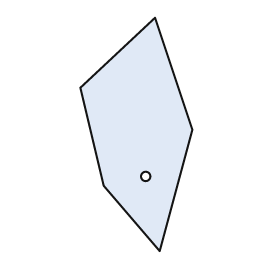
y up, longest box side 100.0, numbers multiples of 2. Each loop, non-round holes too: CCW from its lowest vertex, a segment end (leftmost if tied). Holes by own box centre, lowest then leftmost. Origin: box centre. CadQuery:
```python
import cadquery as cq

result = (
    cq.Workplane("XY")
    .moveTo(10.0, -50.0)
    .lineTo(24.0, 2.0)
    .lineTo(8.0, 50.0)
    .lineTo(-24.0, 20.0)
    .lineTo(-14.0, -22.0)
    .close()
    .moveTo(4.0, -18.0)
    .circle(2.0)
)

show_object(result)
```